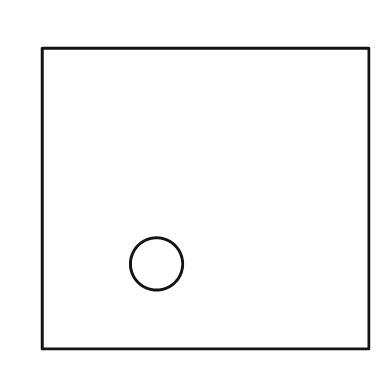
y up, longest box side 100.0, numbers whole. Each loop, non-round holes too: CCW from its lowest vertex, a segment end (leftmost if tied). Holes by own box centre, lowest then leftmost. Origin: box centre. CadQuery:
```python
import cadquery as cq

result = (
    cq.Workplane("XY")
    .moveTo(-50.0, -46.0)
    .lineTo(50.0, -46.0)
    .lineTo(50.0, 46.0)
    .lineTo(-50.0, 46.0)
    .close()
    .moveTo(-15.0, -20.0)
    .circle(8.0)
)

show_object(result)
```